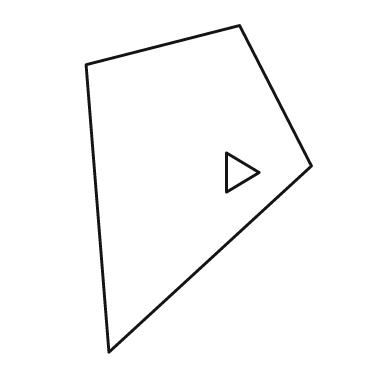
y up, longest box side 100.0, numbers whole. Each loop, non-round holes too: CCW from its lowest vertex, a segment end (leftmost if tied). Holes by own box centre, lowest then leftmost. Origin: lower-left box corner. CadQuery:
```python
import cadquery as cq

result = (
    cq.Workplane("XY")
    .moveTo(7.0, 0.0)
    .lineTo(69.0, 57.0)
    .lineTo(47.0, 100.0)
    .lineTo(0.0, 88.0)
    .close()
    .moveTo(43.0, 49.0)
    .lineTo(53.0, 55.0)
    .lineTo(43.0, 61.0)
    .close()
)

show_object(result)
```